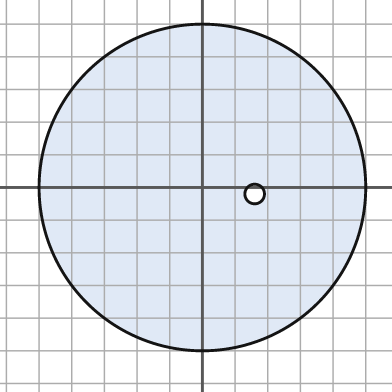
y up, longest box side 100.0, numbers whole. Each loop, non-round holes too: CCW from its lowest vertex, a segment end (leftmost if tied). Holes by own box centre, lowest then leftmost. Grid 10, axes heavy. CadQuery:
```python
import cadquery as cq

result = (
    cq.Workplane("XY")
    .moveTo(0.0, 0.0)
    .circle(50.0)
    .moveTo(16.0, -2.0)
    .circle(3.0)
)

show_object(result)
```